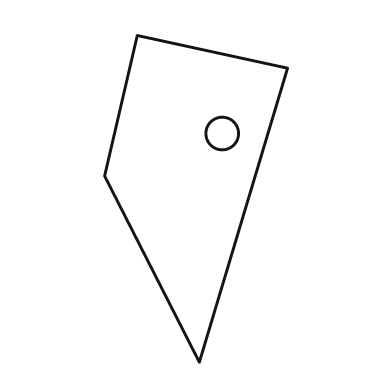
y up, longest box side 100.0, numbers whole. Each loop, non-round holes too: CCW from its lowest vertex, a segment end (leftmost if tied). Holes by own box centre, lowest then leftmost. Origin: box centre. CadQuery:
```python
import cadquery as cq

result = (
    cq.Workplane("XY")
    .moveTo(1.0, -50.0)
    .lineTo(28.0, 40.0)
    .lineTo(-18.0, 50.0)
    .lineTo(-28.0, 7.0)
    .close()
    .moveTo(8.0, 20.0)
    .circle(5.0)
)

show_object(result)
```